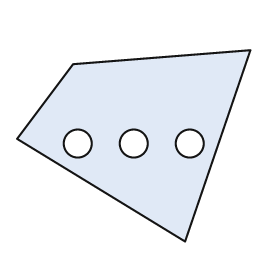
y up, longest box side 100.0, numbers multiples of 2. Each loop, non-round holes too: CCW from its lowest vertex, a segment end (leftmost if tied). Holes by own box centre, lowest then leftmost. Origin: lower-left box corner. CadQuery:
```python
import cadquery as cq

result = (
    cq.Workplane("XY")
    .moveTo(72.0, 0.0)
    .lineTo(100.0, 82.0)
    .lineTo(24.0, 76.0)
    .lineTo(0.0, 44.0)
    .close()
    .moveTo(26.0, 42.0)
    .circle(6.0)
    .moveTo(50.0, 42.0)
    .circle(6.0)
    .moveTo(74.0, 42.0)
    .circle(6.0)
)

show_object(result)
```